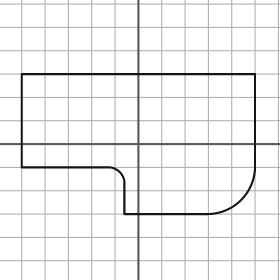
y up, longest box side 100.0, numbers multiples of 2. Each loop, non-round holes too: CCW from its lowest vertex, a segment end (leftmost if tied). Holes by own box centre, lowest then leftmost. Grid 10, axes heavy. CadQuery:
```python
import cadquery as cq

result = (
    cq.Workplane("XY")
    .moveTo(-6.0, -30.0)
    .lineTo(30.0, -30.0)
    .threePointArc((44.0, -24.0), (50.0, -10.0))
    .lineTo(50.0, 30.0)
    .lineTo(-50.0, 30.0)
    .lineTo(-50.0, -10.0)
    .lineTo(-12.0, -10.0)
    .threePointArc((-8.0, -12.0), (-6.0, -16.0))
    .close()
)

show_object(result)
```